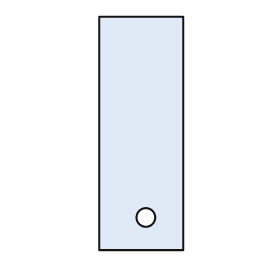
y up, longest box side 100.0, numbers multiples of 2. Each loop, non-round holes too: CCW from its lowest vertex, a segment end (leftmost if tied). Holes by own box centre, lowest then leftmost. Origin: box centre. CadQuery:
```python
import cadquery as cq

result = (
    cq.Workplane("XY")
    .moveTo(-18.0, -50.0)
    .lineTo(18.0, -50.0)
    .lineTo(18.0, 50.0)
    .lineTo(-18.0, 50.0)
    .close()
    .moveTo(2.0, -36.0)
    .circle(4.0)
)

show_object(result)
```